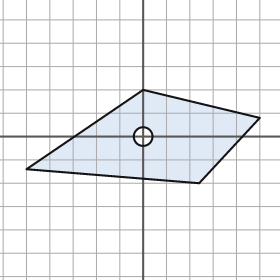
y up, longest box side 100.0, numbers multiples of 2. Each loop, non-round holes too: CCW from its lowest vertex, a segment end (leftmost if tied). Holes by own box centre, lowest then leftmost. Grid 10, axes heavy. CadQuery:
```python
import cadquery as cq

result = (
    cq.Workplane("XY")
    .moveTo(24.0, -20.0)
    .lineTo(50.0, 8.0)
    .lineTo(0.0, 20.0)
    .lineTo(-50.0, -14.0)
    .close()
    .moveTo(0.0, 0.0)
    .circle(4.0)
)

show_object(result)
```